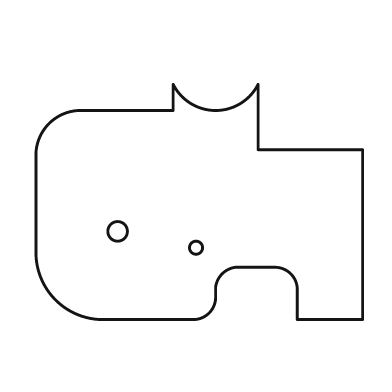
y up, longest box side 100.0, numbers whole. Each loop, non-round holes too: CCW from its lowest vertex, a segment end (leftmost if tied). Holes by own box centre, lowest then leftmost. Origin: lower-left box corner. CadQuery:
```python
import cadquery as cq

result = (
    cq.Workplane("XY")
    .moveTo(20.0, 0.0)
    .lineTo(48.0, 0.0)
    .threePointArc((53.0, 2.0), (55.0, 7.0))
    .lineTo(55.0, 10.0)
    .threePointArc((57.0, 14.0), (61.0, 16.0))
    .lineTo(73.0, 16.0)
    .threePointArc((78.0, 14.0), (80.0, 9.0))
    .lineTo(80.0, 0.0)
    .lineTo(100.0, 0.0)
    .lineTo(100.0, 52.0)
    .lineTo(68.0, 52.0)
    .lineTo(68.0, 72.0)
    .threePointArc((55.0, 64.0), (42.0, 72.0))
    .lineTo(42.0, 64.0)
    .lineTo(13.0, 64.0)
    .threePointArc((4.0, 60.0), (0.0, 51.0))
    .lineTo(0.0, 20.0)
    .threePointArc((6.0, 6.0), (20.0, 0.0))
    .close()
    .moveTo(49.0, 22.0)
    .circle(2.0)
    .moveTo(25.0, 27.0)
    .circle(3.0)
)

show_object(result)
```